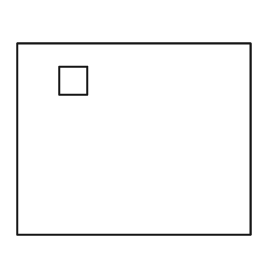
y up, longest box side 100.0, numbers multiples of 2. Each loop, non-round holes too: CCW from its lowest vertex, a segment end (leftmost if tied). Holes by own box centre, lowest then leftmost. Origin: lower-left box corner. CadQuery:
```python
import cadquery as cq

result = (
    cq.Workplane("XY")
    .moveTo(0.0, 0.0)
    .lineTo(100.0, 0.0)
    .lineTo(100.0, 82.0)
    .lineTo(0.0, 82.0)
    .close()
    .moveTo(18.0, 60.0)
    .lineTo(30.0, 60.0)
    .lineTo(30.0, 72.0)
    .lineTo(18.0, 72.0)
    .close()
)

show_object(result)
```